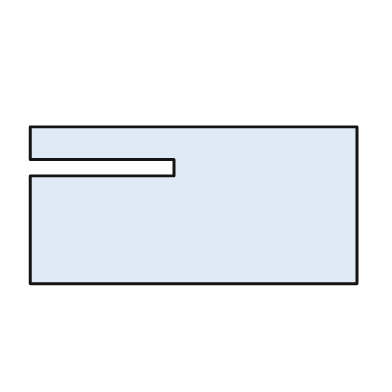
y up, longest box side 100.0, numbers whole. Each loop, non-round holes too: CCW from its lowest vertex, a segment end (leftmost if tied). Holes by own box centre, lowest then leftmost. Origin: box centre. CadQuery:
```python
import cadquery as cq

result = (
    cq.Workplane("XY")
    .moveTo(-50.0, -24.0)
    .lineTo(50.0, -24.0)
    .lineTo(50.0, 24.0)
    .lineTo(-50.0, 24.0)
    .lineTo(-50.0, 14.0)
    .lineTo(-6.0, 14.0)
    .lineTo(-6.0, 9.0)
    .lineTo(-50.0, 9.0)
    .close()
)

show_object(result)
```